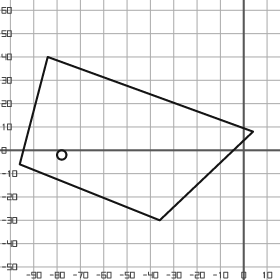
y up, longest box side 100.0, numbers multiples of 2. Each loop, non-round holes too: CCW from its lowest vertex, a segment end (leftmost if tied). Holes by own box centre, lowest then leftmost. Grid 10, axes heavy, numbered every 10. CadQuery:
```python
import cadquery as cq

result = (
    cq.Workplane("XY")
    .moveTo(-36.0, -30.0)
    .lineTo(4.0, 8.0)
    .lineTo(-84.0, 40.0)
    .lineTo(-96.0, -6.0)
    .close()
    .moveTo(-78.0, -2.0)
    .circle(2.0)
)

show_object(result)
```